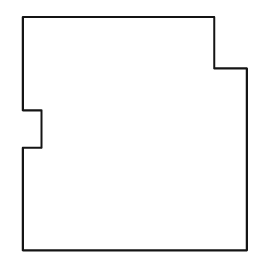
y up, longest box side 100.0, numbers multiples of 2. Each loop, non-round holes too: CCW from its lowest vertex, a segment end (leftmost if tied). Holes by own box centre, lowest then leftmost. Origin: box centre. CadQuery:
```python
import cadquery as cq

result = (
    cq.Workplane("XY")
    .moveTo(-48.0, -50.0)
    .lineTo(48.0, -50.0)
    .lineTo(48.0, 28.0)
    .lineTo(34.0, 28.0)
    .lineTo(34.0, 50.0)
    .lineTo(-48.0, 50.0)
    .lineTo(-48.0, 10.0)
    .lineTo(-40.0, 10.0)
    .lineTo(-40.0, -6.0)
    .lineTo(-48.0, -6.0)
    .close()
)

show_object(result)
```